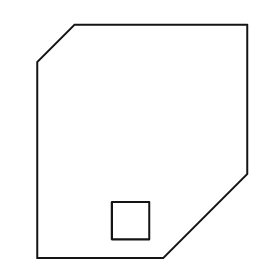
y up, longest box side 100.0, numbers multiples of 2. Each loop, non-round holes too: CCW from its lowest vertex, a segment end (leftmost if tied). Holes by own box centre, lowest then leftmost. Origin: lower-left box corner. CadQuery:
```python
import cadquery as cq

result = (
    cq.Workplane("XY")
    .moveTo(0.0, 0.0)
    .lineTo(54.0, 0.0)
    .lineTo(90.0, 36.0)
    .lineTo(90.0, 100.0)
    .lineTo(16.0, 100.0)
    .lineTo(0.0, 84.0)
    .close()
    .moveTo(32.0, 8.0)
    .lineTo(48.0, 8.0)
    .lineTo(48.0, 24.0)
    .lineTo(32.0, 24.0)
    .close()
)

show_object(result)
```